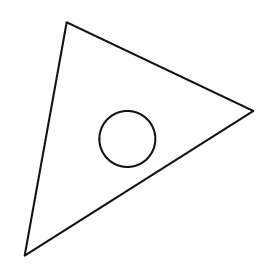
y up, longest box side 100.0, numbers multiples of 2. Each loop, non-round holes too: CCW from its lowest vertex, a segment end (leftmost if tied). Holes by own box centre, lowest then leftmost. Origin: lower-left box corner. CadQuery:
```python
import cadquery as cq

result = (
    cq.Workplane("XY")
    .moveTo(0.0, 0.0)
    .lineTo(98.0, 62.0)
    .lineTo(18.0, 100.0)
    .close()
    .moveTo(44.0, 50.0)
    .circle(12.0)
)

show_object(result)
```